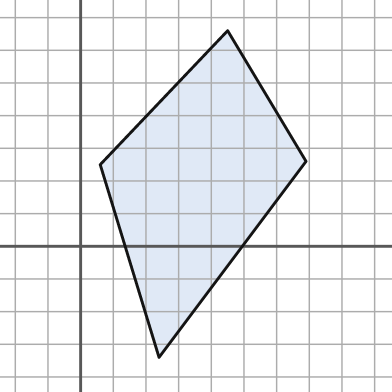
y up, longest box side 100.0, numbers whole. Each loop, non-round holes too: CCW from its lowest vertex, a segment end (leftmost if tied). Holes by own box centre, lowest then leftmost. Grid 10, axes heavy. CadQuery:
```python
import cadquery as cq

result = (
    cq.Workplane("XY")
    .moveTo(24.0, -34.0)
    .lineTo(69.0, 26.0)
    .lineTo(45.0, 66.0)
    .lineTo(6.0, 25.0)
    .close()
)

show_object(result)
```